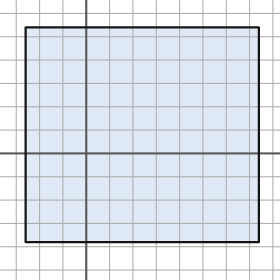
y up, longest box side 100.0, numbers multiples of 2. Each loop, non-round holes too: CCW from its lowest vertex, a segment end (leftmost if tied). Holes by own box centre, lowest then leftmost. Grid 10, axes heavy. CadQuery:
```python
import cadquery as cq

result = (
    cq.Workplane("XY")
    .moveTo(-26.0, -38.0)
    .lineTo(74.0, -38.0)
    .lineTo(74.0, 54.0)
    .lineTo(-26.0, 54.0)
    .close()
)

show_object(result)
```